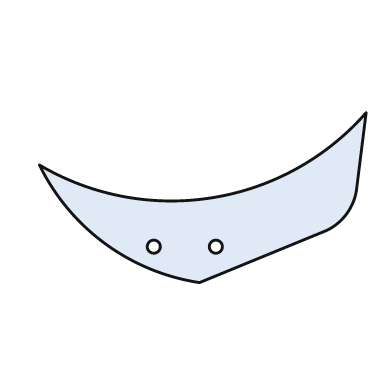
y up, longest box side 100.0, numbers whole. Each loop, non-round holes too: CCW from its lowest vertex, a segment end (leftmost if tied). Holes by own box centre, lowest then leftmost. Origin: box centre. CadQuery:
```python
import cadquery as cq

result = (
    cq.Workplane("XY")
    .moveTo(-1.0, -26.0)
    .lineTo(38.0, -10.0)
    .threePointArc((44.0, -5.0), (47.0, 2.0))
    .lineTo(50.0, 26.0)
    .threePointArc((3.0, 0.0), (-50.0, 10.0))
    .threePointArc((-30.0, -14.0), (-1.0, -26.0))
    .close()
    .moveTo(-15.0, -15.0)
    .circle(2.0)
    .moveTo(4.0, -15.0)
    .circle(2.0)
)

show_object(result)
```